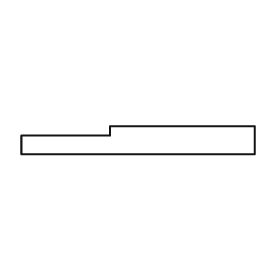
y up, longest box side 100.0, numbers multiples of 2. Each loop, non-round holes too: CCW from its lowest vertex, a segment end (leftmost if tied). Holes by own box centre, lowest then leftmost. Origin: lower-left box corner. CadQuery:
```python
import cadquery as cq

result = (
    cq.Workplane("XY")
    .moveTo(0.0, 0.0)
    .lineTo(100.0, 0.0)
    .lineTo(100.0, 12.0)
    .lineTo(38.0, 12.0)
    .lineTo(38.0, 8.0)
    .lineTo(0.0, 8.0)
    .close()
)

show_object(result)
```